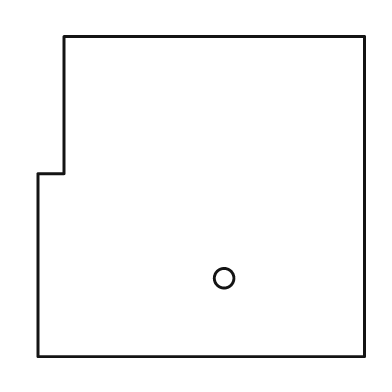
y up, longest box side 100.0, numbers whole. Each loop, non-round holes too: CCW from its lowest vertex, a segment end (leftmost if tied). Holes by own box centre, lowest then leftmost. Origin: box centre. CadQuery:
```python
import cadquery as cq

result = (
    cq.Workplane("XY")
    .moveTo(-50.0, -49.0)
    .lineTo(50.0, -49.0)
    .lineTo(50.0, 49.0)
    .lineTo(-42.0, 49.0)
    .lineTo(-42.0, 7.0)
    .lineTo(-50.0, 7.0)
    .close()
    .moveTo(7.0, -25.0)
    .circle(3.0)
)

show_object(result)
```